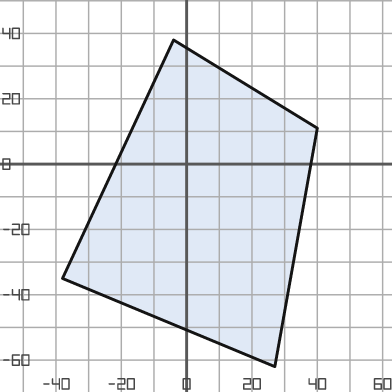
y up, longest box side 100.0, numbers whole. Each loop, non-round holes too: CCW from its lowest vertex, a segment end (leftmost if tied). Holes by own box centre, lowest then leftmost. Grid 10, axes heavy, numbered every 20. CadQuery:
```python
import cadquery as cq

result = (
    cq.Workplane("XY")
    .moveTo(27.0, -62.0)
    .lineTo(40.0, 11.0)
    .lineTo(-4.0, 38.0)
    .lineTo(-38.0, -35.0)
    .close()
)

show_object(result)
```